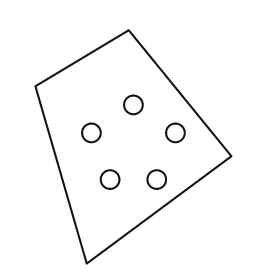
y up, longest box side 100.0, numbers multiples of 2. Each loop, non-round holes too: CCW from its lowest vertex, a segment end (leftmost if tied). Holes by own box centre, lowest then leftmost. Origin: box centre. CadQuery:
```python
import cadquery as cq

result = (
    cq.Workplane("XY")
    .moveTo(-20.0, -50.0)
    .lineTo(42.0, -4.0)
    .lineTo(-2.0, 50.0)
    .lineTo(-42.0, 26.0)
    .close()
    .moveTo(-10.0, -14.0)
    .circle(4.0)
    .moveTo(10.0, -14.0)
    .circle(4.0)
    .moveTo(-18.0, 6.0)
    .circle(4.0)
    .moveTo(18.0, 6.0)
    .circle(4.0)
    .moveTo(0.0, 18.0)
    .circle(4.0)
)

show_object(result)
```